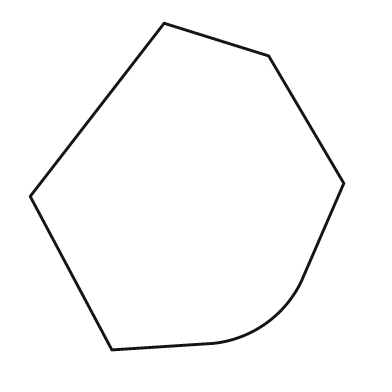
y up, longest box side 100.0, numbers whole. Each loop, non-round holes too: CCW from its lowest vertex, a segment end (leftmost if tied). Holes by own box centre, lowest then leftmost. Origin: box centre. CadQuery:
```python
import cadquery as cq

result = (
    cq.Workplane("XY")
    .moveTo(-23.0, -50.0)
    .lineTo(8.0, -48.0)
    .threePointArc((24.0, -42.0), (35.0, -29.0))
    .lineTo(48.0, 1.0)
    .lineTo(25.0, 40.0)
    .lineTo(-7.0, 50.0)
    .lineTo(-48.0, -3.0)
    .close()
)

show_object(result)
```